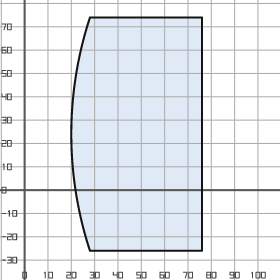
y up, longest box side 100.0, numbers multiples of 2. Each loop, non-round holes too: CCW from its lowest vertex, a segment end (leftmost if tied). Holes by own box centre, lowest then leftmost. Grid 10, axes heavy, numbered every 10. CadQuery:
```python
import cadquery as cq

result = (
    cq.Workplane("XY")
    .moveTo(28.0, -26.0)
    .lineTo(76.0, -26.0)
    .lineTo(76.0, 74.0)
    .lineTo(28.0, 74.0)
    .threePointArc((20.0, 24.0), (28.0, -26.0))
    .close()
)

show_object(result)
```